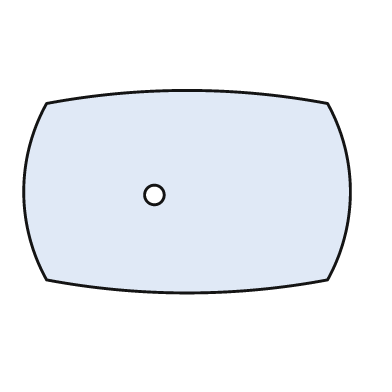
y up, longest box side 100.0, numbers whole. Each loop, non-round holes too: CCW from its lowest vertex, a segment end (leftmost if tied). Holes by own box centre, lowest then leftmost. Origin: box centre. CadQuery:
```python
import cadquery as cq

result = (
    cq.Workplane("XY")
    .moveTo(-43.0, -27.0)
    .threePointArc((0.0, -31.0), (43.0, -27.0))
    .threePointArc((50.0, 0.0), (43.0, 27.0))
    .threePointArc((0.0, 31.0), (-43.0, 27.0))
    .threePointArc((-50.0, 0.0), (-43.0, -27.0))
    .close()
    .moveTo(-10.0, -1.0)
    .circle(3.0)
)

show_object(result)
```